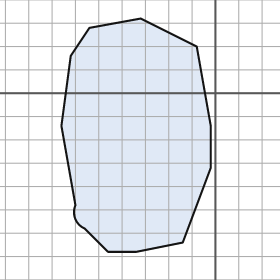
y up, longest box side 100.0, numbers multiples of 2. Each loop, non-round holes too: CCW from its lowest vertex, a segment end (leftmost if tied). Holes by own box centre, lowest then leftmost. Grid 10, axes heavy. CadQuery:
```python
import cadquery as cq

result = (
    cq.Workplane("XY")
    .moveTo(-46.0, -68.0)
    .lineTo(-34.0, -68.0)
    .lineTo(-14.0, -64.0)
    .lineTo(-2.0, -32.0)
    .lineTo(-2.0, -14.0)
    .lineTo(-8.0, 20.0)
    .lineTo(-32.0, 32.0)
    .lineTo(-54.0, 28.0)
    .lineTo(-62.0, 16.0)
    .lineTo(-66.0, -14.0)
    .lineTo(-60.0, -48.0)
    .threePointArc((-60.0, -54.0), (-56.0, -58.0))
    .close()
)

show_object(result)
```